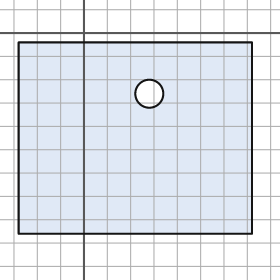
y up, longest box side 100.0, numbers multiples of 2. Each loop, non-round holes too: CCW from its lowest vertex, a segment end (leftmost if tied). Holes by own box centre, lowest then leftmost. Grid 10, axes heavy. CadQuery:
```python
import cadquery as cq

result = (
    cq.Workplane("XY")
    .moveTo(-28.0, -86.0)
    .lineTo(72.0, -86.0)
    .lineTo(72.0, -4.0)
    .lineTo(-28.0, -4.0)
    .close()
    .moveTo(28.0, -26.0)
    .circle(6.0)
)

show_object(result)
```